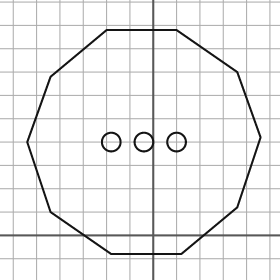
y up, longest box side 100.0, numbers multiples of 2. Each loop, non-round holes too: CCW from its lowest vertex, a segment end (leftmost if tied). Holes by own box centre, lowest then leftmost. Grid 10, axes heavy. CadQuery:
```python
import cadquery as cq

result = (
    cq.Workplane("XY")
    .moveTo(-18.0, -8.0)
    .lineTo(12.0, -8.0)
    .lineTo(36.0, 12.0)
    .lineTo(46.0, 42.0)
    .lineTo(36.0, 70.0)
    .lineTo(10.0, 88.0)
    .lineTo(-20.0, 88.0)
    .lineTo(-44.0, 68.0)
    .lineTo(-54.0, 40.0)
    .lineTo(-44.0, 10.0)
    .close()
    .moveTo(-18.0, 40.0)
    .circle(4.0)
    .moveTo(-4.0, 40.0)
    .circle(4.0)
    .moveTo(10.0, 40.0)
    .circle(4.0)
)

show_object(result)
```